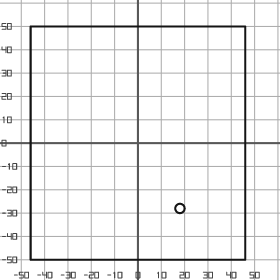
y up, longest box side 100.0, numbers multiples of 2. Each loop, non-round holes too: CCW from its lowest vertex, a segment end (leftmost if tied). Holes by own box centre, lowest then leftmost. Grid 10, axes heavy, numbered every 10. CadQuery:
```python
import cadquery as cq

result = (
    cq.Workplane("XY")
    .moveTo(-46.0, -50.0)
    .lineTo(46.0, -50.0)
    .lineTo(46.0, 50.0)
    .lineTo(-46.0, 50.0)
    .close()
    .moveTo(18.0, -28.0)
    .circle(2.0)
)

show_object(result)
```